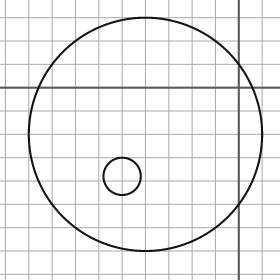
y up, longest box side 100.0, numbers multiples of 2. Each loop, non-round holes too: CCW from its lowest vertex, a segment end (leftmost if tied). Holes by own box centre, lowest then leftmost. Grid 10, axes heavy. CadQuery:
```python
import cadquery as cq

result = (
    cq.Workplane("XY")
    .moveTo(-40.0, -20.0)
    .circle(50.0)
    .moveTo(-50.0, -38.0)
    .circle(8.0)
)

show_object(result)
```